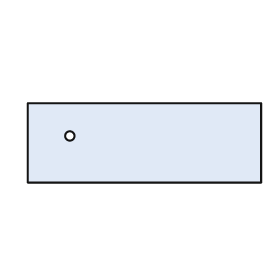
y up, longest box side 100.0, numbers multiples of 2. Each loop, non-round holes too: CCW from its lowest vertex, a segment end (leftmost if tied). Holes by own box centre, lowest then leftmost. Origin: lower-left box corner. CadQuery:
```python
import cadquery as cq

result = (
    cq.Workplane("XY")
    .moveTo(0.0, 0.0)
    .lineTo(100.0, 0.0)
    .lineTo(100.0, 34.0)
    .lineTo(0.0, 34.0)
    .close()
    .moveTo(18.0, 20.0)
    .circle(2.0)
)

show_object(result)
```